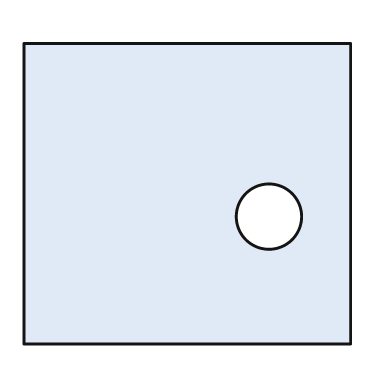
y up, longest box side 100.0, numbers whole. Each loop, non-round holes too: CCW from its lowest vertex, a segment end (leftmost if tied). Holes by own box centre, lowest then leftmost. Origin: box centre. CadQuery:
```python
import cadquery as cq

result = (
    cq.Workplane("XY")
    .moveTo(-50.0, -46.0)
    .lineTo(50.0, -46.0)
    .lineTo(50.0, 46.0)
    .lineTo(-50.0, 46.0)
    .close()
    .moveTo(25.0, -7.0)
    .circle(10.0)
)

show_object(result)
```